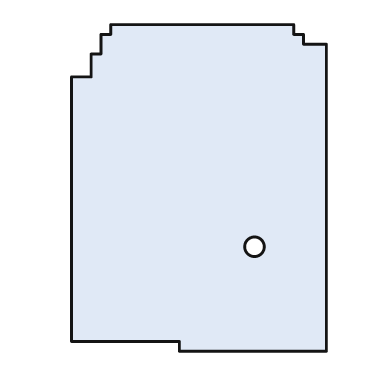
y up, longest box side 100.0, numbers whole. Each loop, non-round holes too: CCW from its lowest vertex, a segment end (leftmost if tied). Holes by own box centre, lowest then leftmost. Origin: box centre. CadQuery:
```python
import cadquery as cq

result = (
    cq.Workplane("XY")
    .moveTo(-6.0, -50.0)
    .lineTo(39.0, -50.0)
    .lineTo(39.0, 44.0)
    .lineTo(32.0, 44.0)
    .lineTo(32.0, 47.0)
    .lineTo(29.0, 47.0)
    .lineTo(29.0, 50.0)
    .lineTo(-27.0, 50.0)
    .lineTo(-27.0, 47.0)
    .lineTo(-30.0, 47.0)
    .lineTo(-30.0, 41.0)
    .lineTo(-33.0, 41.0)
    .lineTo(-33.0, 34.0)
    .lineTo(-39.0, 34.0)
    .lineTo(-39.0, -47.0)
    .lineTo(-6.0, -47.0)
    .close()
    .moveTo(17.0, -18.0)
    .circle(3.0)
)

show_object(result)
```